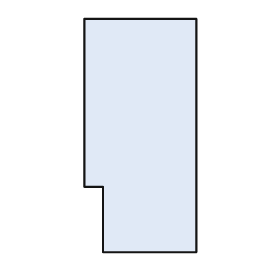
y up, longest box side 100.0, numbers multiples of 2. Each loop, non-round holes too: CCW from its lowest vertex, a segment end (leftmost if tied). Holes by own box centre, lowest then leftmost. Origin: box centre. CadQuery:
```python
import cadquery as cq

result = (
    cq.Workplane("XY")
    .moveTo(-16.0, -50.0)
    .lineTo(24.0, -50.0)
    .lineTo(24.0, 50.0)
    .lineTo(-24.0, 50.0)
    .lineTo(-24.0, -22.0)
    .lineTo(-16.0, -22.0)
    .close()
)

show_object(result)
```